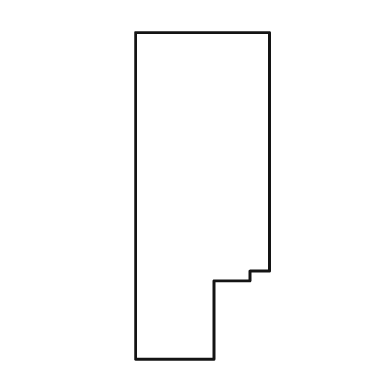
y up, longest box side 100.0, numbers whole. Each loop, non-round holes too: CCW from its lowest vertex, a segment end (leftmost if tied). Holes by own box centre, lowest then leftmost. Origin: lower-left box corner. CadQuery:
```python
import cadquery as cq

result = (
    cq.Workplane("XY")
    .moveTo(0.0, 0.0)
    .lineTo(24.0, 0.0)
    .lineTo(24.0, 24.0)
    .lineTo(35.0, 24.0)
    .lineTo(35.0, 27.0)
    .lineTo(41.0, 27.0)
    .lineTo(41.0, 100.0)
    .lineTo(0.0, 100.0)
    .close()
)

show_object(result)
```